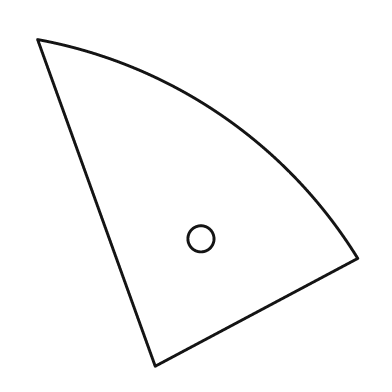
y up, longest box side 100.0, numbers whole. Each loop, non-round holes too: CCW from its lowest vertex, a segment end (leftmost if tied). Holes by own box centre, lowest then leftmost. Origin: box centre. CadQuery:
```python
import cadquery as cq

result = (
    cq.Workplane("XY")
    .moveTo(-13.0, -50.0)
    .lineTo(49.0, -17.0)
    .threePointArc((7.0, 27.0), (-49.0, 50.0))
    .close()
    .moveTo(1.0, -11.0)
    .circle(4.0)
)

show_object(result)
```